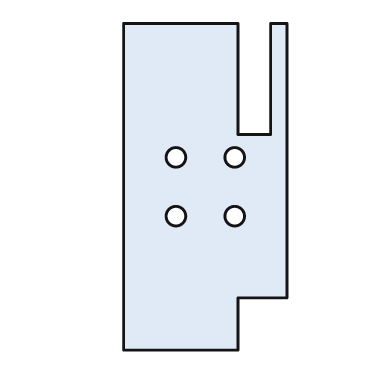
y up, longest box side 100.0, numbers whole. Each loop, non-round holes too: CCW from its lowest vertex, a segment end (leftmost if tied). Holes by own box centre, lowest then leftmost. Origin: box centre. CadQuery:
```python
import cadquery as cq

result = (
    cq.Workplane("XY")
    .moveTo(-25.0, -50.0)
    .lineTo(10.0, -50.0)
    .lineTo(10.0, -34.0)
    .lineTo(25.0, -34.0)
    .lineTo(25.0, 50.0)
    .lineTo(20.0, 50.0)
    .lineTo(20.0, 16.0)
    .lineTo(10.0, 16.0)
    .lineTo(10.0, 50.0)
    .lineTo(-25.0, 50.0)
    .close()
    .moveTo(-9.0, -9.0)
    .circle(3.0)
    .moveTo(9.0, -9.0)
    .circle(3.0)
    .moveTo(-9.0, 9.0)
    .circle(3.0)
    .moveTo(9.0, 9.0)
    .circle(3.0)
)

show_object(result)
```